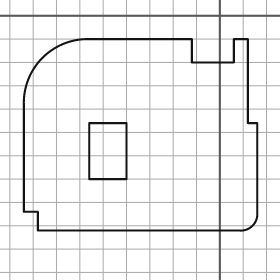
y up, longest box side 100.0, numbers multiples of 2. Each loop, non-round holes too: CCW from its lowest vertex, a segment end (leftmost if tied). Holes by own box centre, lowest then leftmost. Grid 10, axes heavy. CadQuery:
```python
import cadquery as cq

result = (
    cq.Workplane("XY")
    .moveTo(-78.0, -92.0)
    .lineTo(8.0, -92.0)
    .threePointArc((14.0, -90.0), (16.0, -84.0))
    .lineTo(16.0, -46.0)
    .lineTo(12.0, -46.0)
    .lineTo(12.0, -10.0)
    .lineTo(6.0, -10.0)
    .lineTo(6.0, -20.0)
    .lineTo(-12.0, -20.0)
    .lineTo(-12.0, -10.0)
    .lineTo(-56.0, -10.0)
    .threePointArc((-76.0, -18.0), (-84.0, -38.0))
    .lineTo(-84.0, -84.0)
    .lineTo(-78.0, -84.0)
    .close()
    .moveTo(-56.0, -70.0)
    .lineTo(-40.0, -70.0)
    .lineTo(-40.0, -46.0)
    .lineTo(-56.0, -46.0)
    .close()
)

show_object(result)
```